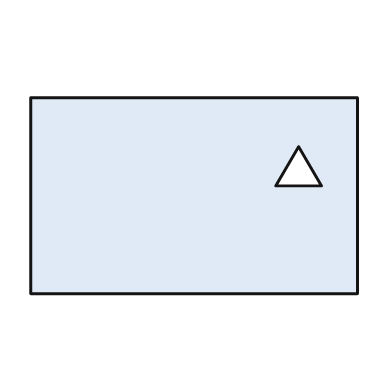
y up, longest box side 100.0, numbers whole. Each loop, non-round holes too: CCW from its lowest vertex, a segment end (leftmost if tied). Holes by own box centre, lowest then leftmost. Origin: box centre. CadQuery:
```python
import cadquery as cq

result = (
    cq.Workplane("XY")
    .moveTo(-50.0, -30.0)
    .lineTo(50.0, -30.0)
    .lineTo(50.0, 30.0)
    .lineTo(-50.0, 30.0)
    .close()
    .moveTo(25.0, 3.0)
    .lineTo(39.0, 3.0)
    .lineTo(32.0, 15.0)
    .close()
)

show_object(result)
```